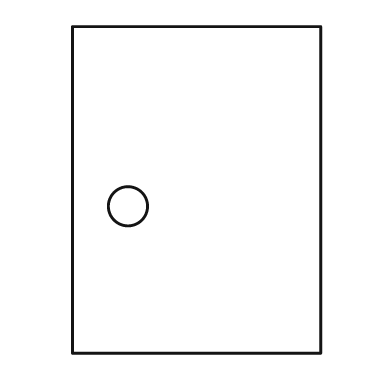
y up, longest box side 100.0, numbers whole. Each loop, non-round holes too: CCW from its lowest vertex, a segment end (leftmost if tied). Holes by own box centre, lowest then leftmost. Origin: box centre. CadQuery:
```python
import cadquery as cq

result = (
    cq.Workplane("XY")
    .moveTo(-38.0, -50.0)
    .lineTo(38.0, -50.0)
    .lineTo(38.0, 50.0)
    .lineTo(-38.0, 50.0)
    .close()
    .moveTo(-21.0, -5.0)
    .circle(6.0)
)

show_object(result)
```